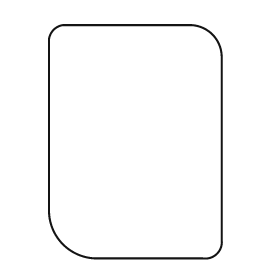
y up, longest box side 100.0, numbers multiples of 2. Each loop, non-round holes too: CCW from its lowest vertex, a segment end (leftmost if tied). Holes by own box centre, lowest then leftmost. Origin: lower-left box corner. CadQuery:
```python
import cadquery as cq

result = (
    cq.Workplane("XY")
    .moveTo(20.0, 0.0)
    .lineTo(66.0, 0.0)
    .threePointArc((72.0, 2.0), (74.0, 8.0))
    .lineTo(74.0, 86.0)
    .threePointArc((70.0, 96.0), (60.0, 100.0))
    .lineTo(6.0, 100.0)
    .threePointArc((2.0, 98.0), (0.0, 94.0))
    .lineTo(0.0, 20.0)
    .threePointArc((6.0, 6.0), (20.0, 0.0))
    .close()
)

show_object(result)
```